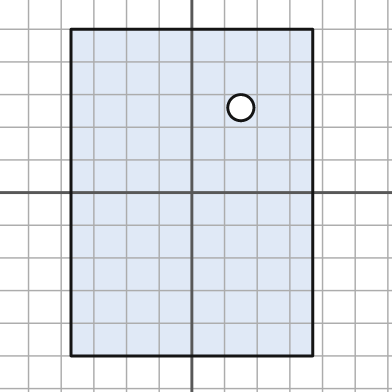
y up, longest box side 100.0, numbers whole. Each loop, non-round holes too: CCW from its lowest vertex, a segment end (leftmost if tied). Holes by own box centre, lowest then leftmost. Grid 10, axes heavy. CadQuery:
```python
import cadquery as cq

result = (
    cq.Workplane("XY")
    .moveTo(-37.0, -50.0)
    .lineTo(37.0, -50.0)
    .lineTo(37.0, 50.0)
    .lineTo(-37.0, 50.0)
    .close()
    .moveTo(15.0, 26.0)
    .circle(4.0)
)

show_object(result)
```